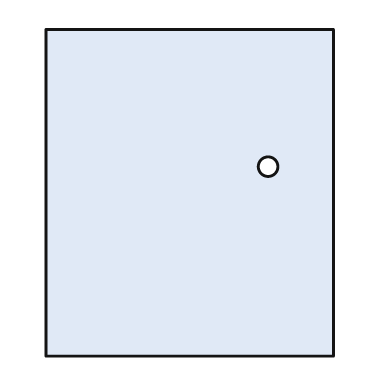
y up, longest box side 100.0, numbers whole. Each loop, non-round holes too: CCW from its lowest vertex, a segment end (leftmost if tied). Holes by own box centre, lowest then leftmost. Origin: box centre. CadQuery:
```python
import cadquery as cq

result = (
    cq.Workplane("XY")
    .moveTo(-44.0, -50.0)
    .lineTo(44.0, -50.0)
    .lineTo(44.0, 50.0)
    .lineTo(-44.0, 50.0)
    .close()
    .moveTo(24.0, 8.0)
    .circle(3.0)
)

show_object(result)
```